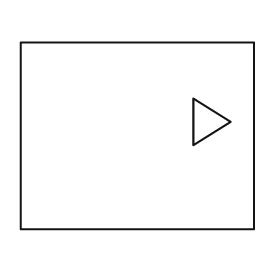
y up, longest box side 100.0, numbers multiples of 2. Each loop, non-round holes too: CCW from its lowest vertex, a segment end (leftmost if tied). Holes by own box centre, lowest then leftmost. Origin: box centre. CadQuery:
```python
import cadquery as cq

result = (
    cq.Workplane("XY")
    .moveTo(-50.0, -40.0)
    .lineTo(50.0, -40.0)
    .lineTo(50.0, 40.0)
    .lineTo(-50.0, 40.0)
    .close()
    .moveTo(24.0, -4.0)
    .lineTo(40.0, 6.0)
    .lineTo(24.0, 16.0)
    .close()
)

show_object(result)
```